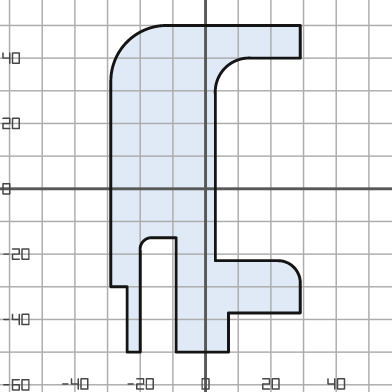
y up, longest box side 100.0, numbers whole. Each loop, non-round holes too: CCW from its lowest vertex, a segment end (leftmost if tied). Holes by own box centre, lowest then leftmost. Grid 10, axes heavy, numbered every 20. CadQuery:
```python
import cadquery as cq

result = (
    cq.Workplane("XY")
    .moveTo(-24.0, -50.0)
    .lineTo(-20.0, -50.0)
    .lineTo(-20.0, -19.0)
    .threePointArc((-19.0, -16.0), (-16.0, -15.0))
    .lineTo(-9.0, -15.0)
    .lineTo(-9.0, -50.0)
    .lineTo(7.0, -50.0)
    .lineTo(7.0, -38.0)
    .lineTo(29.0, -38.0)
    .lineTo(29.0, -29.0)
    .threePointArc((27.0, -24.0), (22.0, -22.0))
    .lineTo(3.0, -22.0)
    .lineTo(3.0, 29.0)
    .threePointArc((6.0, 37.0), (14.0, 40.0))
    .lineTo(29.0, 40.0)
    .lineTo(29.0, 50.0)
    .lineTo(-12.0, 50.0)
    .threePointArc((-24.0, 45.0), (-29.0, 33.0))
    .lineTo(-29.0, -30.0)
    .lineTo(-24.0, -30.0)
    .close()
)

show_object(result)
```